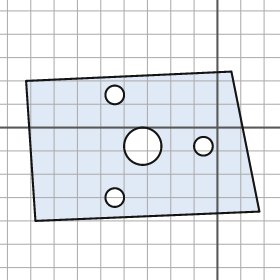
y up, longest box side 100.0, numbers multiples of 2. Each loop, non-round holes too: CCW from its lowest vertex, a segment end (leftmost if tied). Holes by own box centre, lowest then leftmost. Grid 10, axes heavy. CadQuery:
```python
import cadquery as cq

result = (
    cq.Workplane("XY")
    .moveTo(-78.0, -40.0)
    .lineTo(18.0, -36.0)
    .lineTo(6.0, 24.0)
    .lineTo(-82.0, 20.0)
    .close()
    .moveTo(-44.0, -30.0)
    .circle(4.0)
    .moveTo(-32.0, -8.0)
    .circle(8.0)
    .moveTo(-6.0, -8.0)
    .circle(4.0)
    .moveTo(-44.0, 14.0)
    .circle(4.0)
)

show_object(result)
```